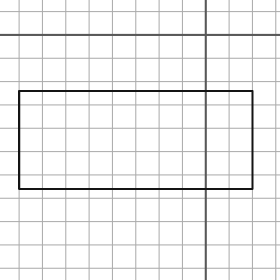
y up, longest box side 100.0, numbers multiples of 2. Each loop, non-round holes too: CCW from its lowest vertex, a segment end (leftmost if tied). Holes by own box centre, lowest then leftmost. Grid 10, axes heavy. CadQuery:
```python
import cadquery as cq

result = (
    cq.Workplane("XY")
    .moveTo(-80.0, -66.0)
    .lineTo(20.0, -66.0)
    .lineTo(20.0, -24.0)
    .lineTo(-80.0, -24.0)
    .close()
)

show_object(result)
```